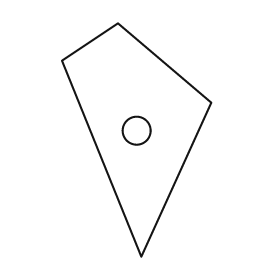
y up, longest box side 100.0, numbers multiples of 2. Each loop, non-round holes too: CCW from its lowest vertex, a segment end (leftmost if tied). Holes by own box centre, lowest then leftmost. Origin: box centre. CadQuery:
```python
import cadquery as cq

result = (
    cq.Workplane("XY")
    .moveTo(2.0, -50.0)
    .lineTo(32.0, 16.0)
    .lineTo(-8.0, 50.0)
    .lineTo(-32.0, 34.0)
    .close()
    .moveTo(0.0, 4.0)
    .circle(6.0)
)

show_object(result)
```